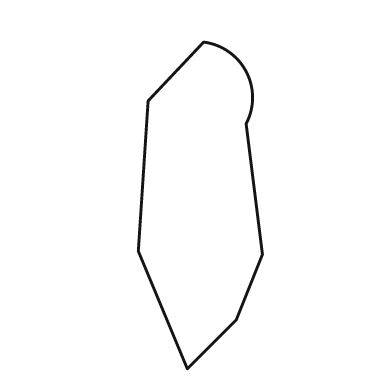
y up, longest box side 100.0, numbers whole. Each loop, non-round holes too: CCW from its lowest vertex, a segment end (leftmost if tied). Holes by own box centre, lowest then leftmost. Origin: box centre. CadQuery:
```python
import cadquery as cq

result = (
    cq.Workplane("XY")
    .moveTo(-4.0, -50.0)
    .lineTo(11.0, -35.0)
    .lineTo(19.0, -15.0)
    .lineTo(14.0, 25.0)
    .threePointArc((14.0, 41.0), (1.0, 50.0))
    .lineTo(-16.0, 32.0)
    .lineTo(-19.0, -14.0)
    .close()
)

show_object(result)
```